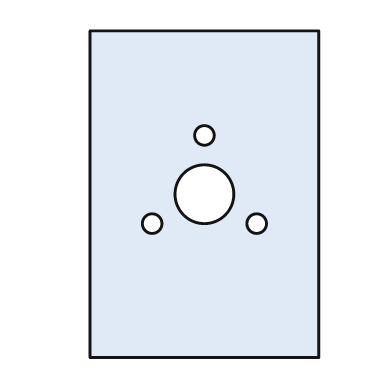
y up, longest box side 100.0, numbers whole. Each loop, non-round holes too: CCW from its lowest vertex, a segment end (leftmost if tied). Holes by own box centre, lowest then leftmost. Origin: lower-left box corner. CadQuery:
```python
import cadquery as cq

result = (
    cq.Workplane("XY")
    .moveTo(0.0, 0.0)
    .lineTo(70.0, 0.0)
    .lineTo(70.0, 100.0)
    .lineTo(0.0, 100.0)
    .close()
    .moveTo(19.0, 41.0)
    .circle(3.0)
    .moveTo(51.0, 41.0)
    .circle(3.0)
    .moveTo(35.0, 50.0)
    .circle(9.0)
    .moveTo(35.0, 68.0)
    .circle(3.0)
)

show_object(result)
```